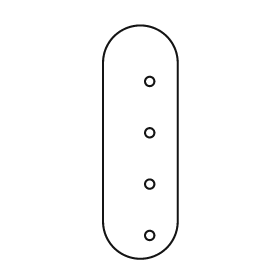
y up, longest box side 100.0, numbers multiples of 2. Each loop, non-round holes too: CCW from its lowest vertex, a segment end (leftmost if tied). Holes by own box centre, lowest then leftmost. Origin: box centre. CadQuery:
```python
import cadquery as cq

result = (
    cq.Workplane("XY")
    .moveTo(-16.0, -34.0)
    .threePointArc((0.0, -50.0), (16.0, -34.0))
    .lineTo(16.0, 34.0)
    .threePointArc((0.0, 50.0), (-16.0, 34.0))
    .close()
    .moveTo(4.0, -40.0)
    .circle(2.0)
    .moveTo(4.0, -18.0)
    .circle(2.0)
    .moveTo(4.0, 4.0)
    .circle(2.0)
    .moveTo(4.0, 26.0)
    .circle(2.0)
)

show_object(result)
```